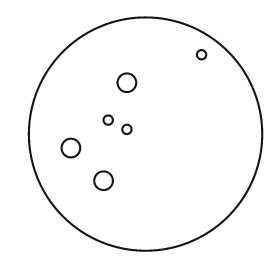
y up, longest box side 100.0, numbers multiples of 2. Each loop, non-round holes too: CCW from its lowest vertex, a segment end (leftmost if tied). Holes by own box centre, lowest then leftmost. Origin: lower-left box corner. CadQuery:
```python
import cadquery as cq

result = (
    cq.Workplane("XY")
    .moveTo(50.0, 50.0)
    .circle(50.0)
    .moveTo(32.0, 30.0)
    .circle(4.0)
    .moveTo(18.0, 44.0)
    .circle(4.0)
    .moveTo(42.0, 52.0)
    .circle(2.0)
    .moveTo(34.0, 56.0)
    .circle(2.0)
    .moveTo(42.0, 72.0)
    .circle(4.0)
    .moveTo(74.0, 84.0)
    .circle(2.0)
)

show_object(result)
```